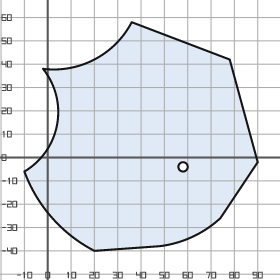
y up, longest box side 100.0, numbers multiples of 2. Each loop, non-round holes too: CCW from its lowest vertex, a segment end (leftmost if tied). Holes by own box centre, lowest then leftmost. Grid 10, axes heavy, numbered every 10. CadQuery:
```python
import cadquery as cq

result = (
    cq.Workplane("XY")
    .moveTo(20.0, -40.0)
    .lineTo(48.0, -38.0)
    .threePointArc((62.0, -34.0), (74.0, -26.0))
    .lineTo(90.0, -2.0)
    .lineTo(78.0, 42.0)
    .lineTo(36.0, 58.0)
    .threePointArc((20.0, 42.0), (-2.0, 38.0))
    .threePointArc((4.0, 14.0), (-10.0, -6.0))
    .threePointArc((2.0, -26.0), (20.0, -40.0))
    .close()
    .moveTo(58.0, -4.0)
    .circle(2.0)
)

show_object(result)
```